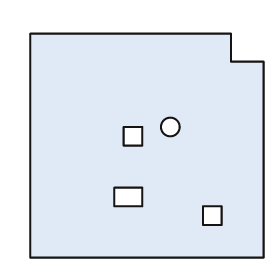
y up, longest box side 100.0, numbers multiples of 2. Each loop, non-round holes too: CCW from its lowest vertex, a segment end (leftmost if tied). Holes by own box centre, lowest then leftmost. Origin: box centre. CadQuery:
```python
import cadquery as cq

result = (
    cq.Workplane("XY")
    .moveTo(-50.0, -48.0)
    .lineTo(50.0, -48.0)
    .lineTo(50.0, 36.0)
    .lineTo(36.0, 36.0)
    .lineTo(36.0, 48.0)
    .lineTo(-50.0, 48.0)
    .close()
    .moveTo(24.0, -34.0)
    .lineTo(32.0, -34.0)
    .lineTo(32.0, -26.0)
    .lineTo(24.0, -26.0)
    .close()
    .moveTo(-14.0, -26.0)
    .lineTo(-2.0, -26.0)
    .lineTo(-2.0, -18.0)
    .lineTo(-14.0, -18.0)
    .close()
    .moveTo(-10.0, 0.0)
    .lineTo(-2.0, 0.0)
    .lineTo(-2.0, 8.0)
    .lineTo(-10.0, 8.0)
    .close()
    .moveTo(10.0, 8.0)
    .circle(4.0)
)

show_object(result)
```